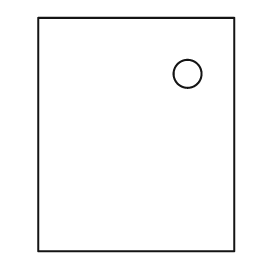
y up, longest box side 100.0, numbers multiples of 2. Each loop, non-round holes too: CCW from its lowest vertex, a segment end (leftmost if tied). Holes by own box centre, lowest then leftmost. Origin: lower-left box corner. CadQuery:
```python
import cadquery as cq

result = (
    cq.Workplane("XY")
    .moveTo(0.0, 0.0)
    .lineTo(84.0, 0.0)
    .lineTo(84.0, 100.0)
    .lineTo(0.0, 100.0)
    .close()
    .moveTo(64.0, 76.0)
    .circle(6.0)
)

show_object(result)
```